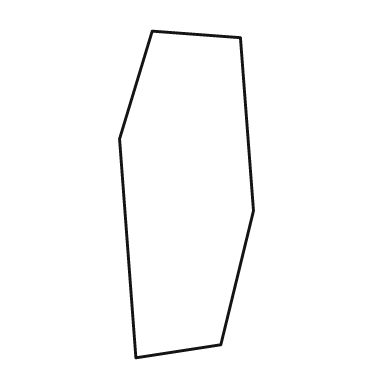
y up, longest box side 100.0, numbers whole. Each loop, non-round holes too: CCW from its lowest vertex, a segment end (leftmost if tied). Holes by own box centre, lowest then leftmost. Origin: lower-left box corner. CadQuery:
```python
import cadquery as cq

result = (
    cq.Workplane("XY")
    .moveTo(5.0, 0.0)
    .lineTo(31.0, 4.0)
    .lineTo(41.0, 45.0)
    .lineTo(37.0, 98.0)
    .lineTo(10.0, 100.0)
    .lineTo(0.0, 67.0)
    .close()
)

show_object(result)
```